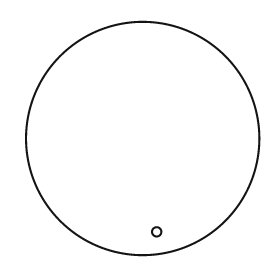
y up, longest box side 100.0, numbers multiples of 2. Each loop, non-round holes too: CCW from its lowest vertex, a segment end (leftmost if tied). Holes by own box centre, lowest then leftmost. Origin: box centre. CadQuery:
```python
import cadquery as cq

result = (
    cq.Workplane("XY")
    .moveTo(0.0, 0.0)
    .circle(50.0)
    .moveTo(6.0, -40.0)
    .circle(2.0)
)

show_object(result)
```